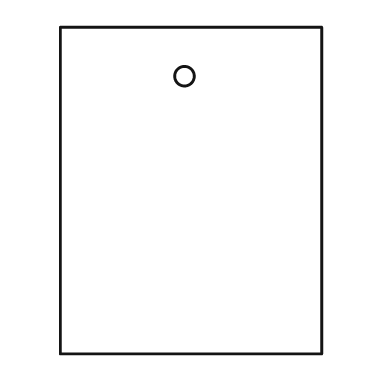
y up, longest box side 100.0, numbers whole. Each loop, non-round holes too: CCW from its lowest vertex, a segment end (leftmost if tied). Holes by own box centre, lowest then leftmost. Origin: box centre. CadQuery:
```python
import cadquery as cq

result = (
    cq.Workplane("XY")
    .moveTo(-40.0, -50.0)
    .lineTo(40.0, -50.0)
    .lineTo(40.0, 50.0)
    .lineTo(-40.0, 50.0)
    .close()
    .moveTo(-2.0, 35.0)
    .circle(3.0)
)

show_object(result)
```